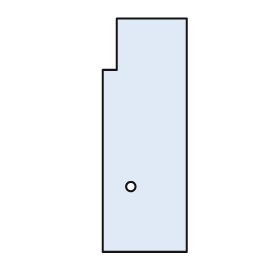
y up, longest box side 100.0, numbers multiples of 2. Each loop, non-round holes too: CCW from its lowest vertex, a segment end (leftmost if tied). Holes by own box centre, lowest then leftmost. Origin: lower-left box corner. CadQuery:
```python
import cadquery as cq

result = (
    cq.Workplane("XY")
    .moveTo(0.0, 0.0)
    .lineTo(36.0, 0.0)
    .lineTo(36.0, 100.0)
    .lineTo(6.0, 100.0)
    .lineTo(6.0, 78.0)
    .lineTo(0.0, 78.0)
    .close()
    .moveTo(12.0, 28.0)
    .circle(2.0)
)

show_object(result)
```